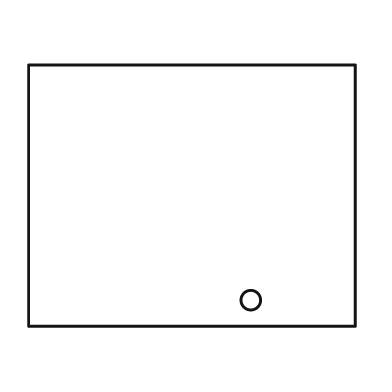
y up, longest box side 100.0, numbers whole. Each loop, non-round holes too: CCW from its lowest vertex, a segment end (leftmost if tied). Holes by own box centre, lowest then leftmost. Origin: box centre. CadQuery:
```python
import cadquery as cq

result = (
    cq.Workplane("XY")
    .moveTo(-50.0, -40.0)
    .lineTo(50.0, -40.0)
    .lineTo(50.0, 40.0)
    .lineTo(-50.0, 40.0)
    .close()
    .moveTo(18.0, -32.0)
    .circle(3.0)
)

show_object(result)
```